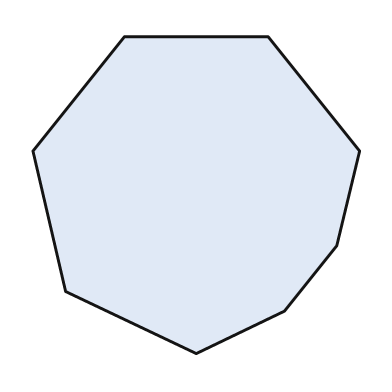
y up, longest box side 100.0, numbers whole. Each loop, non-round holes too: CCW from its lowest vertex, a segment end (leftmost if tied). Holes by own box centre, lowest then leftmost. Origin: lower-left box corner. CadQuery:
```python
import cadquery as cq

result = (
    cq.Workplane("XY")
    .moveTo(50.0, 0.0)
    .lineTo(77.0, 13.0)
    .lineTo(93.0, 33.0)
    .lineTo(100.0, 62.0)
    .lineTo(72.0, 97.0)
    .lineTo(28.0, 97.0)
    .lineTo(0.0, 62.0)
    .lineTo(10.0, 19.0)
    .close()
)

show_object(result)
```